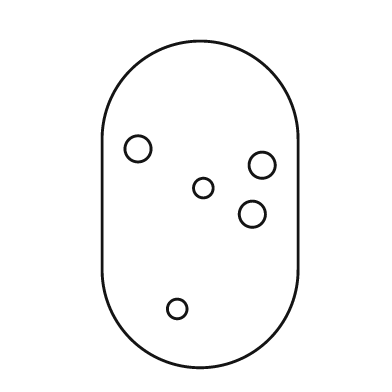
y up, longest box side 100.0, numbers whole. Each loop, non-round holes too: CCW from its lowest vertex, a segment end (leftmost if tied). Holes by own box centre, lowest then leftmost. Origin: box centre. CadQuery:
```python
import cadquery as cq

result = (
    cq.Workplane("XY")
    .moveTo(-30.0, -20.0)
    .threePointArc((0.0, -50.0), (30.0, -20.0))
    .lineTo(30.0, 20.0)
    .threePointArc((0.0, 50.0), (-30.0, 20.0))
    .close()
    .moveTo(-7.0, -32.0)
    .circle(3.0)
    .moveTo(16.0, -3.0)
    .circle(4.0)
    .moveTo(1.0, 5.0)
    .circle(3.0)
    .moveTo(19.0, 12.0)
    .circle(4.0)
    .moveTo(-19.0, 17.0)
    .circle(4.0)
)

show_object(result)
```